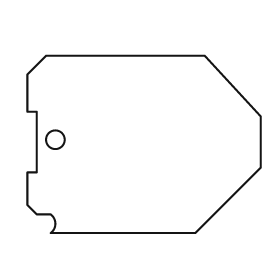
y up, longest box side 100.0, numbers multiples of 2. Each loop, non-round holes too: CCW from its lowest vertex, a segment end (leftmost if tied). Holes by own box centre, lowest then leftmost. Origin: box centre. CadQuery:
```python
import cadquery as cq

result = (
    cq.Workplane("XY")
    .moveTo(-40.0, -38.0)
    .lineTo(22.0, -38.0)
    .lineTo(50.0, -10.0)
    .lineTo(50.0, 12.0)
    .lineTo(26.0, 38.0)
    .lineTo(-42.0, 38.0)
    .lineTo(-50.0, 30.0)
    .lineTo(-50.0, 14.0)
    .lineTo(-46.0, 14.0)
    .lineTo(-46.0, -12.0)
    .lineTo(-50.0, -12.0)
    .lineTo(-50.0, -26.0)
    .lineTo(-46.0, -30.0)
    .lineTo(-40.0, -30.0)
    .threePointArc((-38.0, -34.0), (-40.0, -38.0))
    .close()
    .moveTo(-38.0, 2.0)
    .circle(4.0)
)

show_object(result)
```